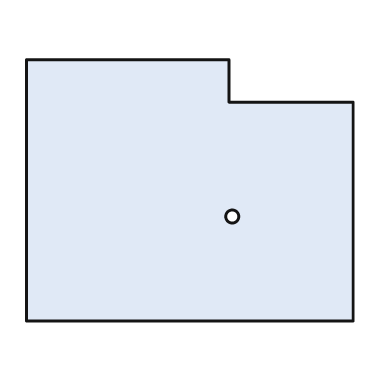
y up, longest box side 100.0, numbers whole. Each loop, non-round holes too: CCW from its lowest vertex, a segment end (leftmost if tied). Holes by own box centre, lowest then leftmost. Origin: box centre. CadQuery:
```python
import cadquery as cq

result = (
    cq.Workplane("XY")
    .moveTo(-50.0, -40.0)
    .lineTo(50.0, -40.0)
    .lineTo(50.0, 27.0)
    .lineTo(12.0, 27.0)
    .lineTo(12.0, 40.0)
    .lineTo(-50.0, 40.0)
    .close()
    .moveTo(13.0, -8.0)
    .circle(2.0)
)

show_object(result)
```